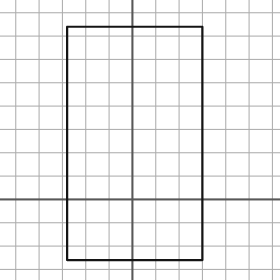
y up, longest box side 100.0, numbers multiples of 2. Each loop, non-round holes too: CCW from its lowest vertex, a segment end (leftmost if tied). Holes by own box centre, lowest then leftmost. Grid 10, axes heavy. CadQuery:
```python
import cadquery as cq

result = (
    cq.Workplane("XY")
    .moveTo(-28.0, -26.0)
    .lineTo(30.0, -26.0)
    .lineTo(30.0, 74.0)
    .lineTo(-28.0, 74.0)
    .close()
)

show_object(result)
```